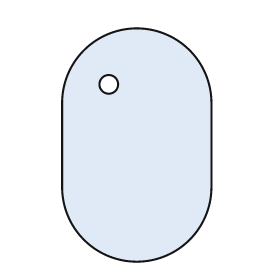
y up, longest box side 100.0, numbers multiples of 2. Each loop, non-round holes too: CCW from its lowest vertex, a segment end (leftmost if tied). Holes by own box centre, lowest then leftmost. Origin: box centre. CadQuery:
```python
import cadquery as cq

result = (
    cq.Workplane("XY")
    .moveTo(-32.0, -18.0)
    .threePointArc((0.0, -50.0), (32.0, -18.0))
    .lineTo(32.0, 18.0)
    .threePointArc((0.0, 50.0), (-32.0, 18.0))
    .close()
    .moveTo(-12.0, 26.0)
    .circle(4.0)
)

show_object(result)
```